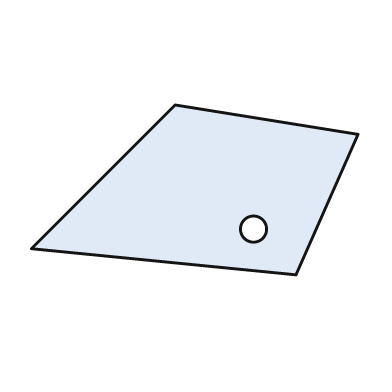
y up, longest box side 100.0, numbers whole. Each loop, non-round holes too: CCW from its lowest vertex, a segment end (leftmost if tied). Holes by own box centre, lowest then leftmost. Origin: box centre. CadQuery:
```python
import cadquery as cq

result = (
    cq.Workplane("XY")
    .moveTo(31.0, -26.0)
    .lineTo(50.0, 17.0)
    .lineTo(-6.0, 26.0)
    .lineTo(-50.0, -18.0)
    .close()
    .moveTo(18.0, -12.0)
    .circle(4.0)
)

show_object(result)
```